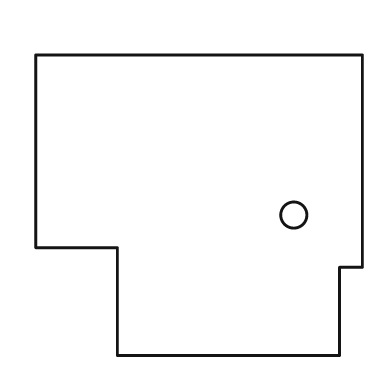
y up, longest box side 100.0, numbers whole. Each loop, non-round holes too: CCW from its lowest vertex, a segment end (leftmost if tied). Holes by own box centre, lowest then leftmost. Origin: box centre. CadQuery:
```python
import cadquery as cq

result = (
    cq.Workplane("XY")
    .moveTo(-25.0, -46.0)
    .lineTo(43.0, -46.0)
    .lineTo(43.0, -19.0)
    .lineTo(50.0, -19.0)
    .lineTo(50.0, 46.0)
    .lineTo(-50.0, 46.0)
    .lineTo(-50.0, -13.0)
    .lineTo(-25.0, -13.0)
    .close()
    .moveTo(29.0, -3.0)
    .circle(4.0)
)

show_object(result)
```